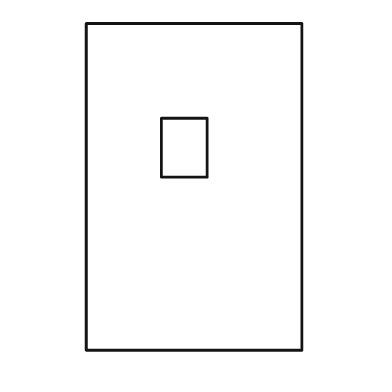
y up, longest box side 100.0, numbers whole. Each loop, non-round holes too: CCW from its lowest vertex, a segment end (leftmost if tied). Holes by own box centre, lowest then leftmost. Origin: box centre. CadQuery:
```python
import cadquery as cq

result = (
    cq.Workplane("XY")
    .moveTo(-33.0, -50.0)
    .lineTo(33.0, -50.0)
    .lineTo(33.0, 50.0)
    .lineTo(-33.0, 50.0)
    .close()
    .moveTo(-10.0, 3.0)
    .lineTo(4.0, 3.0)
    .lineTo(4.0, 21.0)
    .lineTo(-10.0, 21.0)
    .close()
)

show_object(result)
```